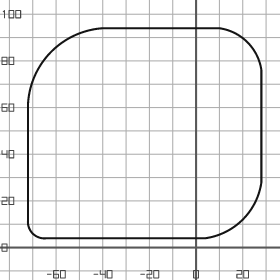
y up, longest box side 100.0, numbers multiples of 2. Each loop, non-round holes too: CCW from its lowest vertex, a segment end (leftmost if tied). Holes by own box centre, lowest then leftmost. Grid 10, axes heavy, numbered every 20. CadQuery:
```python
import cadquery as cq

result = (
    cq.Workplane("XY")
    .moveTo(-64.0, 4.0)
    .lineTo(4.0, 4.0)
    .threePointArc((20.0, 12.0), (28.0, 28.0))
    .lineTo(28.0, 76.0)
    .threePointArc((22.0, 88.0), (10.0, 94.0))
    .lineTo(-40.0, 94.0)
    .threePointArc((-62.0, 84.0), (-72.0, 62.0))
    .lineTo(-72.0, 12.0)
    .threePointArc((-70.0, 6.0), (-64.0, 4.0))
    .close()
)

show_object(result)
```